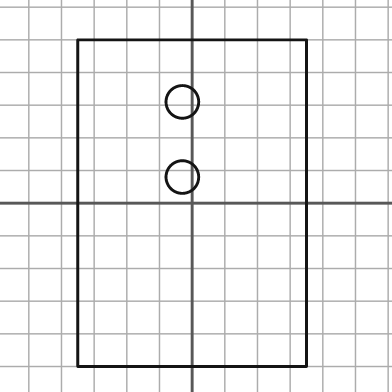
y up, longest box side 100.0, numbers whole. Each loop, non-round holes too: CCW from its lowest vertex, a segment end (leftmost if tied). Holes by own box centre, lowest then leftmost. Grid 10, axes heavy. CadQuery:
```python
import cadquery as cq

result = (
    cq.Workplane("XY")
    .moveTo(-35.0, -50.0)
    .lineTo(35.0, -50.0)
    .lineTo(35.0, 50.0)
    .lineTo(-35.0, 50.0)
    .close()
    .moveTo(-3.0, 8.0)
    .circle(5.0)
    .moveTo(-3.0, 31.0)
    .circle(5.0)
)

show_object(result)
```